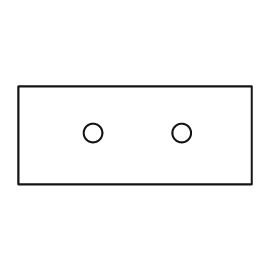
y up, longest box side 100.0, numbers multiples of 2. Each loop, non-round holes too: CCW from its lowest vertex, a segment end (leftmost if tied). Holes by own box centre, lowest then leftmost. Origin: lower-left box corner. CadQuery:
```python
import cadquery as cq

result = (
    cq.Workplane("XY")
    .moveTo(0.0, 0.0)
    .lineTo(100.0, 0.0)
    .lineTo(100.0, 42.0)
    .lineTo(0.0, 42.0)
    .close()
    .moveTo(32.0, 22.0)
    .circle(4.0)
    .moveTo(70.0, 22.0)
    .circle(4.0)
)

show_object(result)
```